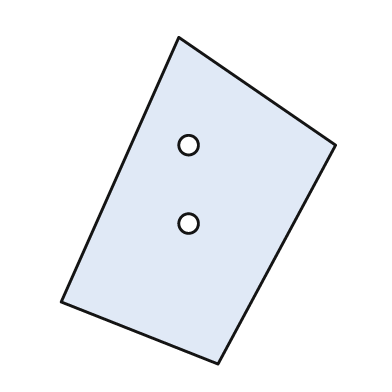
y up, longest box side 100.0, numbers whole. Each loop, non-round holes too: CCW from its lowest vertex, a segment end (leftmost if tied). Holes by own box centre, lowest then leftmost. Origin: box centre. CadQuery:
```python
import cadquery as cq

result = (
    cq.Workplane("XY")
    .moveTo(6.0, -50.0)
    .lineTo(42.0, 17.0)
    .lineTo(-6.0, 50.0)
    .lineTo(-42.0, -31.0)
    .close()
    .moveTo(-3.0, -7.0)
    .circle(3.0)
    .moveTo(-3.0, 17.0)
    .circle(3.0)
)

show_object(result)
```